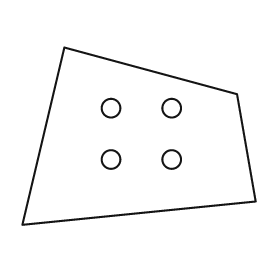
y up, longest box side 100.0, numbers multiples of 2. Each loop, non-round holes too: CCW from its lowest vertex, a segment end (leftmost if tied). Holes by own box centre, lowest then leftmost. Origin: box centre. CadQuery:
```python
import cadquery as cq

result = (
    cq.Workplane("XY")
    .moveTo(-50.0, -38.0)
    .lineTo(50.0, -28.0)
    .lineTo(42.0, 18.0)
    .lineTo(-32.0, 38.0)
    .close()
    .moveTo(-12.0, -10.0)
    .circle(4.0)
    .moveTo(14.0, -10.0)
    .circle(4.0)
    .moveTo(-12.0, 12.0)
    .circle(4.0)
    .moveTo(14.0, 12.0)
    .circle(4.0)
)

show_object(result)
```